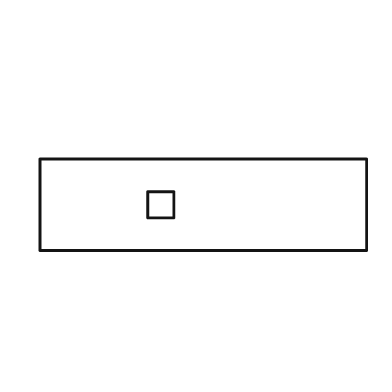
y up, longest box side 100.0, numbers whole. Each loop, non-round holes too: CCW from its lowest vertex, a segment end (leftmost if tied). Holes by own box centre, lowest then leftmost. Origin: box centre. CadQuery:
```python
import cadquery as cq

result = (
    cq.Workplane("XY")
    .moveTo(-50.0, -14.0)
    .lineTo(50.0, -14.0)
    .lineTo(50.0, 14.0)
    .lineTo(-50.0, 14.0)
    .close()
    .moveTo(-17.0, -4.0)
    .lineTo(-9.0, -4.0)
    .lineTo(-9.0, 4.0)
    .lineTo(-17.0, 4.0)
    .close()
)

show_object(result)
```